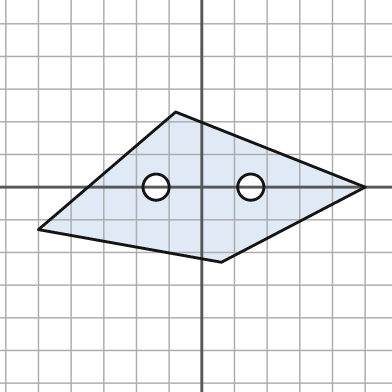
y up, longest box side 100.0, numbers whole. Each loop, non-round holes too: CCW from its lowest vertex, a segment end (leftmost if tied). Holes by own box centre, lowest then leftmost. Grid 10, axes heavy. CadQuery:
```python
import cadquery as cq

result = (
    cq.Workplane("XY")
    .moveTo(6.0, -23.0)
    .lineTo(50.0, 0.0)
    .lineTo(-8.0, 23.0)
    .lineTo(-50.0, -13.0)
    .close()
    .moveTo(-14.0, 0.0)
    .circle(4.0)
    .moveTo(15.0, 0.0)
    .circle(4.0)
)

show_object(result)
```